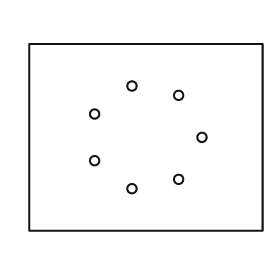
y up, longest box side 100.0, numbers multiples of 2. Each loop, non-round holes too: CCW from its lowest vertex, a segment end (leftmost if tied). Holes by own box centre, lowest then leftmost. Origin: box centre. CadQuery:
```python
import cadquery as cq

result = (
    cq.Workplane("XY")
    .moveTo(-50.0, -40.0)
    .lineTo(50.0, -40.0)
    .lineTo(50.0, 40.0)
    .lineTo(-50.0, 40.0)
    .close()
    .moveTo(-6.0, -22.0)
    .circle(2.0)
    .moveTo(14.0, -18.0)
    .circle(2.0)
    .moveTo(-22.0, -10.0)
    .circle(2.0)
    .moveTo(24.0, 0.0)
    .circle(2.0)
    .moveTo(-22.0, 10.0)
    .circle(2.0)
    .moveTo(14.0, 18.0)
    .circle(2.0)
    .moveTo(-6.0, 22.0)
    .circle(2.0)
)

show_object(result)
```